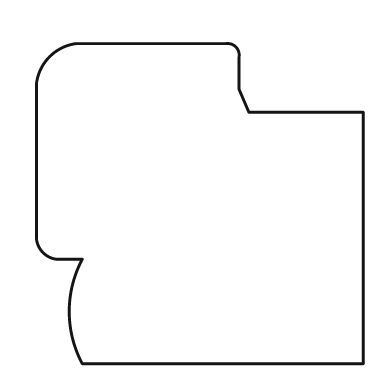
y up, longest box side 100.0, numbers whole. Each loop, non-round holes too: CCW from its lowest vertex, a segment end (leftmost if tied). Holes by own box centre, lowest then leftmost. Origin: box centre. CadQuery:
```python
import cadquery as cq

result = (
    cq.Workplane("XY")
    .moveTo(-36.0, -49.0)
    .lineTo(50.0, -49.0)
    .lineTo(50.0, 28.0)
    .lineTo(15.0, 28.0)
    .lineTo(12.0, 35.0)
    .lineTo(12.0, 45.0)
    .threePointArc((11.0, 48.0), (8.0, 49.0))
    .lineTo(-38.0, 49.0)
    .threePointArc((-46.0, 45.0), (-50.0, 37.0))
    .lineTo(-50.0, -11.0)
    .threePointArc((-48.0, -15.0), (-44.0, -17.0))
    .lineTo(-36.0, -17.0)
    .threePointArc((-40.0, -33.0), (-36.0, -49.0))
    .close()
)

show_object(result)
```